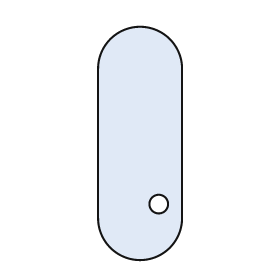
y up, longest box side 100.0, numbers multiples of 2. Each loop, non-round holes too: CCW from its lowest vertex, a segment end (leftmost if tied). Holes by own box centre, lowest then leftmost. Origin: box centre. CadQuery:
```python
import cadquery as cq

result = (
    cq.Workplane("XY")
    .moveTo(-18.0, -32.0)
    .threePointArc((0.0, -50.0), (18.0, -32.0))
    .lineTo(18.0, 32.0)
    .threePointArc((0.0, 50.0), (-18.0, 32.0))
    .close()
    .moveTo(8.0, -26.0)
    .circle(4.0)
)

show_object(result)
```